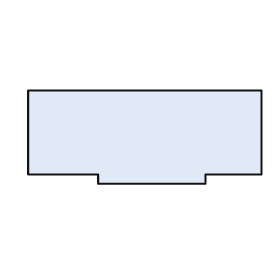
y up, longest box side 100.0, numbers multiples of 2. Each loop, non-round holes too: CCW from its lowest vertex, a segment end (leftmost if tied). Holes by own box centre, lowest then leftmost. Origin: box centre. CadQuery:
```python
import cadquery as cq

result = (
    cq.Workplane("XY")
    .moveTo(-20.0, -20.0)
    .lineTo(26.0, -20.0)
    .lineTo(26.0, -16.0)
    .lineTo(50.0, -16.0)
    .lineTo(50.0, 20.0)
    .lineTo(-50.0, 20.0)
    .lineTo(-50.0, -16.0)
    .lineTo(-20.0, -16.0)
    .close()
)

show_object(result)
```